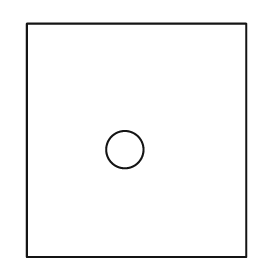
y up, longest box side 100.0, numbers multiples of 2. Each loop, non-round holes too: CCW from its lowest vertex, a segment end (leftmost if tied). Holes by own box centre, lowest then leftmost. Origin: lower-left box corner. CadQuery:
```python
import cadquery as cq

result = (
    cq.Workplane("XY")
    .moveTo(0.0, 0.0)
    .lineTo(94.0, 0.0)
    .lineTo(94.0, 100.0)
    .lineTo(0.0, 100.0)
    .close()
    .moveTo(42.0, 46.0)
    .circle(8.0)
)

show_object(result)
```